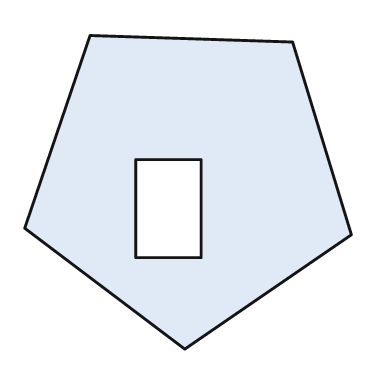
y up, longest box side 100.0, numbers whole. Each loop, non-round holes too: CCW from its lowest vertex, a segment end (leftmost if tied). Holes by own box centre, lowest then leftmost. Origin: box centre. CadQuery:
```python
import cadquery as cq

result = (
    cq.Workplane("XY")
    .moveTo(-1.0, -48.0)
    .lineTo(50.0, -13.0)
    .lineTo(32.0, 46.0)
    .lineTo(-30.0, 48.0)
    .lineTo(-50.0, -11.0)
    .close()
    .moveTo(-16.0, -20.0)
    .lineTo(4.0, -20.0)
    .lineTo(4.0, 10.0)
    .lineTo(-16.0, 10.0)
    .close()
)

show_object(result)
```